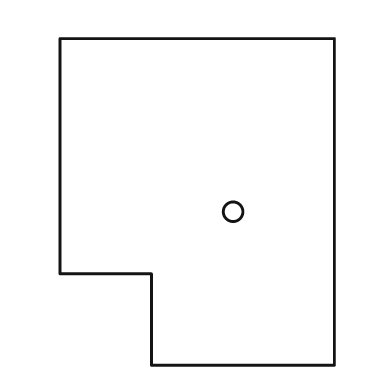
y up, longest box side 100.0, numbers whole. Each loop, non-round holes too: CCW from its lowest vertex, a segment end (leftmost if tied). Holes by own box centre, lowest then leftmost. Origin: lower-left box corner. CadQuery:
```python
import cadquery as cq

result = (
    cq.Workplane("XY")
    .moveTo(28.0, 0.0)
    .lineTo(84.0, 0.0)
    .lineTo(84.0, 100.0)
    .lineTo(0.0, 100.0)
    .lineTo(0.0, 28.0)
    .lineTo(28.0, 28.0)
    .close()
    .moveTo(53.0, 47.0)
    .circle(3.0)
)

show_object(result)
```